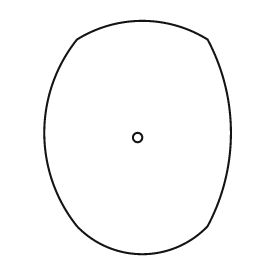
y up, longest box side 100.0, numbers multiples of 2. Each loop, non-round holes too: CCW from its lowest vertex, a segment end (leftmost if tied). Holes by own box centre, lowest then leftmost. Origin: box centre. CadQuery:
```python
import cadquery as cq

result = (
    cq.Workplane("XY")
    .moveTo(-26.0, -38.0)
    .threePointArc((2.0, -50.0), (30.0, -38.0))
    .threePointArc((40.0, 2.0), (30.0, 42.0))
    .threePointArc((2.0, 50.0), (-26.0, 42.0))
    .threePointArc((-40.0, 2.0), (-26.0, -38.0))
    .close()
    .moveTo(0.0, 0.0)
    .circle(2.0)
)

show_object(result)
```